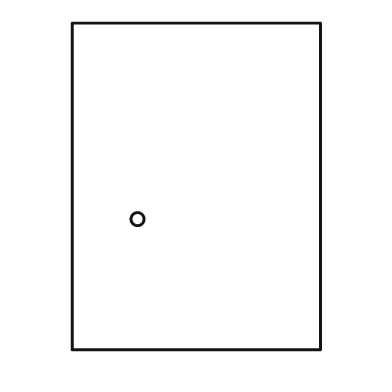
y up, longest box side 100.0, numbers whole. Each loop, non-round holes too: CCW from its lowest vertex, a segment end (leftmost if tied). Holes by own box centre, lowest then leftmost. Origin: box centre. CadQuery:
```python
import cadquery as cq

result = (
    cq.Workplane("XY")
    .moveTo(-38.0, -50.0)
    .lineTo(38.0, -50.0)
    .lineTo(38.0, 50.0)
    .lineTo(-38.0, 50.0)
    .close()
    .moveTo(-18.0, -10.0)
    .circle(2.0)
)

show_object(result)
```